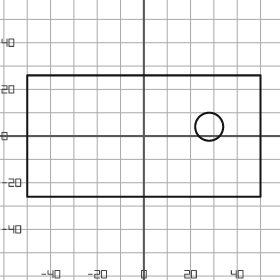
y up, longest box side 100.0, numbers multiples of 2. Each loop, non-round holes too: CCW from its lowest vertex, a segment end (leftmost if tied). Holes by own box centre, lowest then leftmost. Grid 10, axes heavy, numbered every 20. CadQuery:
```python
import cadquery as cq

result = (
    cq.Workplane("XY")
    .moveTo(-50.0, -26.0)
    .lineTo(50.0, -26.0)
    .lineTo(50.0, 26.0)
    .lineTo(-50.0, 26.0)
    .close()
    .moveTo(28.0, 4.0)
    .circle(6.0)
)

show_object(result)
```